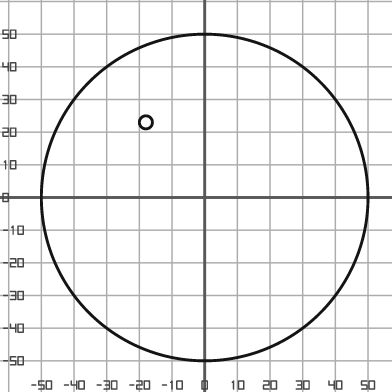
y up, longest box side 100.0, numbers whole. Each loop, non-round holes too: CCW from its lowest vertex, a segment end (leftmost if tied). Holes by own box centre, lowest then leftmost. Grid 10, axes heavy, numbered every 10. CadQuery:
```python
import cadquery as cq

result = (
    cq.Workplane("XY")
    .moveTo(0.0, 0.0)
    .circle(50.0)
    .moveTo(-18.0, 23.0)
    .circle(2.0)
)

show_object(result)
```